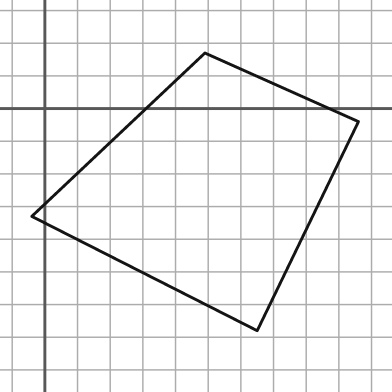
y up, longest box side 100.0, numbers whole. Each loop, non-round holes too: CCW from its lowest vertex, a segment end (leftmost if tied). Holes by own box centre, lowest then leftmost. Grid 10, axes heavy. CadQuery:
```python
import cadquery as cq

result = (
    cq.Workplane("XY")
    .moveTo(65.0, -68.0)
    .lineTo(96.0, -4.0)
    .lineTo(49.0, 17.0)
    .lineTo(-4.0, -33.0)
    .close()
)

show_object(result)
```